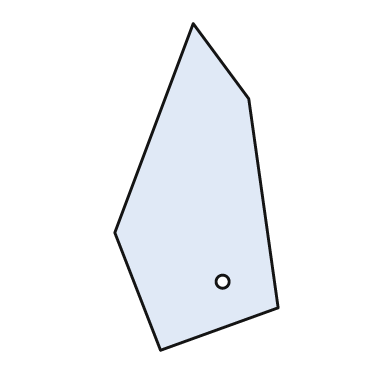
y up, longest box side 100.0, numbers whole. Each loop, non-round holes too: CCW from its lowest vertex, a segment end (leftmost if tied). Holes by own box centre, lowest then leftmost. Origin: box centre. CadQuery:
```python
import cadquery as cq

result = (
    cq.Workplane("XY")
    .moveTo(-11.0, -50.0)
    .lineTo(25.0, -37.0)
    .lineTo(16.0, 27.0)
    .lineTo(-1.0, 50.0)
    .lineTo(-25.0, -14.0)
    .close()
    .moveTo(8.0, -29.0)
    .circle(2.0)
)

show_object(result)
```